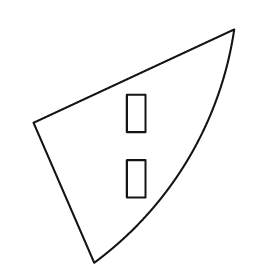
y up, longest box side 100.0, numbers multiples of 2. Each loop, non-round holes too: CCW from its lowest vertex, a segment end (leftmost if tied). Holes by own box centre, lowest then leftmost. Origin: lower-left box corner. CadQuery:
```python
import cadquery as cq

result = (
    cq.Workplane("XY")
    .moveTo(26.0, 0.0)
    .threePointArc((66.0, 44.0), (86.0, 100.0))
    .lineTo(0.0, 60.0)
    .close()
    .moveTo(40.0, 28.0)
    .lineTo(48.0, 28.0)
    .lineTo(48.0, 44.0)
    .lineTo(40.0, 44.0)
    .close()
    .moveTo(40.0, 56.0)
    .lineTo(48.0, 56.0)
    .lineTo(48.0, 72.0)
    .lineTo(40.0, 72.0)
    .close()
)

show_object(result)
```